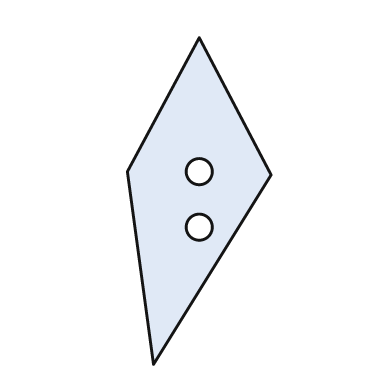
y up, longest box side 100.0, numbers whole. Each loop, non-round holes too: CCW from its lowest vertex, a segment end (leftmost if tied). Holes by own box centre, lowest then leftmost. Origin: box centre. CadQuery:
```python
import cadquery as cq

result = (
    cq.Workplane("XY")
    .moveTo(-14.0, -50.0)
    .lineTo(22.0, 8.0)
    .lineTo(0.0, 50.0)
    .lineTo(-22.0, 9.0)
    .close()
    .moveTo(0.0, -8.0)
    .circle(4.0)
    .moveTo(0.0, 9.0)
    .circle(4.0)
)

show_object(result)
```